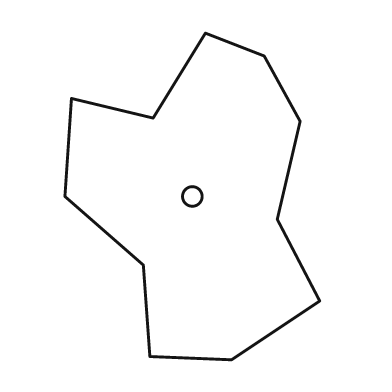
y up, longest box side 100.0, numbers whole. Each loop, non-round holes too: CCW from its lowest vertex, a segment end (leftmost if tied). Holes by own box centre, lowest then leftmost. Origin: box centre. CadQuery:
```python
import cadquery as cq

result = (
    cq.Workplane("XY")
    .moveTo(12.0, -50.0)
    .lineTo(39.0, -32.0)
    .lineTo(26.0, -7.0)
    .lineTo(33.0, 23.0)
    .lineTo(22.0, 43.0)
    .lineTo(4.0, 50.0)
    .lineTo(-12.0, 24.0)
    .lineTo(-37.0, 30.0)
    .lineTo(-39.0, 0.0)
    .lineTo(-15.0, -21.0)
    .lineTo(-13.0, -49.0)
    .close()
    .moveTo(0.0, 0.0)
    .circle(3.0)
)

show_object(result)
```